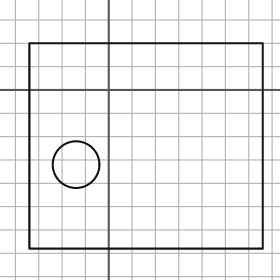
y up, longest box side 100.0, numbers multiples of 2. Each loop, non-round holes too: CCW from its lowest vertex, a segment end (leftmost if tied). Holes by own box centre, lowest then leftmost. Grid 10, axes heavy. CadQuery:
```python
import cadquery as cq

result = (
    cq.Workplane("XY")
    .moveTo(-34.0, -68.0)
    .lineTo(66.0, -68.0)
    .lineTo(66.0, 20.0)
    .lineTo(-34.0, 20.0)
    .close()
    .moveTo(-14.0, -32.0)
    .circle(10.0)
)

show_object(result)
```